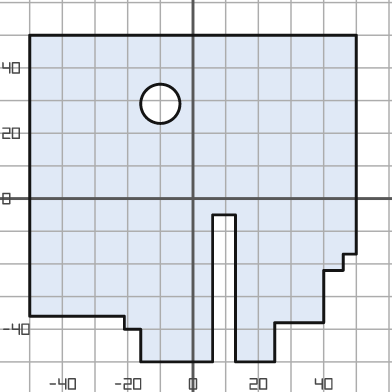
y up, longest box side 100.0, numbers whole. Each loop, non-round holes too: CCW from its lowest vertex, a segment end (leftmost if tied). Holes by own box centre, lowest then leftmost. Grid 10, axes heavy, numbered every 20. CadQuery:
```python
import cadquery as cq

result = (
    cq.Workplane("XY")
    .moveTo(-16.0, -50.0)
    .lineTo(6.0, -50.0)
    .lineTo(6.0, -5.0)
    .lineTo(13.0, -5.0)
    .lineTo(13.0, -50.0)
    .lineTo(25.0, -50.0)
    .lineTo(25.0, -38.0)
    .lineTo(40.0, -38.0)
    .lineTo(40.0, -22.0)
    .lineTo(46.0, -22.0)
    .lineTo(46.0, -17.0)
    .lineTo(50.0, -17.0)
    .lineTo(50.0, 50.0)
    .lineTo(-50.0, 50.0)
    .lineTo(-50.0, -36.0)
    .lineTo(-21.0, -36.0)
    .lineTo(-21.0, -40.0)
    .lineTo(-16.0, -40.0)
    .close()
    .moveTo(-10.0, 29.0)
    .circle(6.0)
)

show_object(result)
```